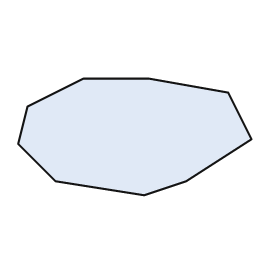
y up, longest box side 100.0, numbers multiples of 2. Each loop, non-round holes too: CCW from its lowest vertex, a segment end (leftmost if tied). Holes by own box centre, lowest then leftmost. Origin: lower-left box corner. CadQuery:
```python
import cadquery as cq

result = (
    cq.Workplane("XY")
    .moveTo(54.0, 0.0)
    .lineTo(72.0, 6.0)
    .lineTo(100.0, 24.0)
    .lineTo(90.0, 44.0)
    .lineTo(56.0, 50.0)
    .lineTo(28.0, 50.0)
    .lineTo(4.0, 38.0)
    .lineTo(0.0, 22.0)
    .lineTo(16.0, 6.0)
    .close()
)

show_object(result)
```